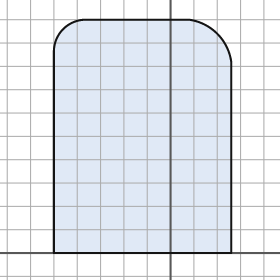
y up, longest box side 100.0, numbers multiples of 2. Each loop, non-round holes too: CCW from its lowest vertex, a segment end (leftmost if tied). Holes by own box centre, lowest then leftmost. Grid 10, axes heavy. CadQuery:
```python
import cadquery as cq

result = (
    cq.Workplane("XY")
    .moveTo(-50.0, 0.0)
    .lineTo(26.0, 0.0)
    .lineTo(26.0, 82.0)
    .threePointArc((20.0, 94.0), (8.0, 100.0))
    .lineTo(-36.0, 100.0)
    .threePointArc((-46.0, 96.0), (-50.0, 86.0))
    .close()
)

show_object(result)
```